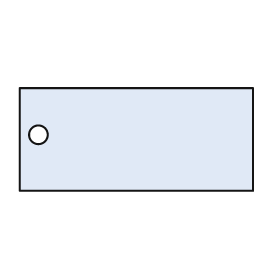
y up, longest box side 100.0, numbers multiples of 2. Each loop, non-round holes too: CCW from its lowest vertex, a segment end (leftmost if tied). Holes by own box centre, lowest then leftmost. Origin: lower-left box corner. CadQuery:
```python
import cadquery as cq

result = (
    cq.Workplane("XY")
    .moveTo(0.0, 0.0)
    .lineTo(100.0, 0.0)
    .lineTo(100.0, 44.0)
    .lineTo(0.0, 44.0)
    .close()
    .moveTo(8.0, 24.0)
    .circle(4.0)
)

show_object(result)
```